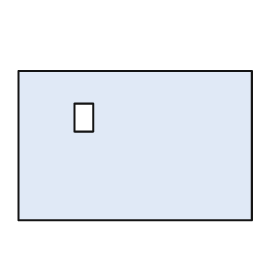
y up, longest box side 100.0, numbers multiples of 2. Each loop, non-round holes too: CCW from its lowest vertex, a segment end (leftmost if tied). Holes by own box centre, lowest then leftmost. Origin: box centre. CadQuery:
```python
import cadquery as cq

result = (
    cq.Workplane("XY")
    .moveTo(-50.0, -32.0)
    .lineTo(50.0, -32.0)
    .lineTo(50.0, 32.0)
    .lineTo(-50.0, 32.0)
    .close()
    .moveTo(-26.0, 6.0)
    .lineTo(-18.0, 6.0)
    .lineTo(-18.0, 18.0)
    .lineTo(-26.0, 18.0)
    .close()
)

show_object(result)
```